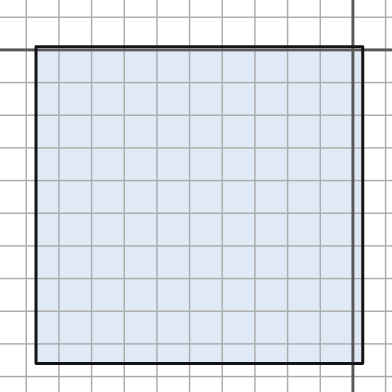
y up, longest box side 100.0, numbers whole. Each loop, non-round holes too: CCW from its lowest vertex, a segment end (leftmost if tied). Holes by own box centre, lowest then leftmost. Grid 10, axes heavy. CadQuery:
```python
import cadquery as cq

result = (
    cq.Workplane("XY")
    .moveTo(-97.0, -96.0)
    .lineTo(3.0, -96.0)
    .lineTo(3.0, 1.0)
    .lineTo(-97.0, 1.0)
    .close()
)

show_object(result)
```